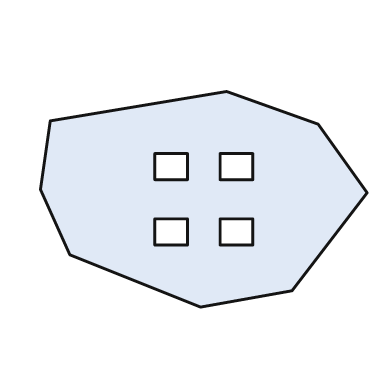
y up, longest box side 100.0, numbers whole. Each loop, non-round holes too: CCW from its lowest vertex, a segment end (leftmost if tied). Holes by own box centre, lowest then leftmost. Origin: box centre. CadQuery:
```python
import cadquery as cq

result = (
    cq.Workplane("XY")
    .moveTo(-1.0, -33.0)
    .lineTo(27.0, -28.0)
    .lineTo(50.0, 2.0)
    .lineTo(35.0, 23.0)
    .lineTo(7.0, 33.0)
    .lineTo(-47.0, 24.0)
    .lineTo(-50.0, 3.0)
    .lineTo(-41.0, -17.0)
    .close()
    .moveTo(-15.0, -14.0)
    .lineTo(-5.0, -14.0)
    .lineTo(-5.0, -6.0)
    .lineTo(-15.0, -6.0)
    .close()
    .moveTo(5.0, -14.0)
    .lineTo(15.0, -14.0)
    .lineTo(15.0, -6.0)
    .lineTo(5.0, -6.0)
    .close()
    .moveTo(-15.0, 6.0)
    .lineTo(-5.0, 6.0)
    .lineTo(-5.0, 14.0)
    .lineTo(-15.0, 14.0)
    .close()
    .moveTo(5.0, 6.0)
    .lineTo(15.0, 6.0)
    .lineTo(15.0, 14.0)
    .lineTo(5.0, 14.0)
    .close()
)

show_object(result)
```